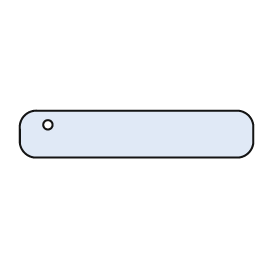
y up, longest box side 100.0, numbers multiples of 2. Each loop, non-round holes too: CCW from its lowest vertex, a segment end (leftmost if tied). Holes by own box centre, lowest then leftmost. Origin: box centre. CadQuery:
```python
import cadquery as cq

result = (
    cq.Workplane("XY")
    .moveTo(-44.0, -10.0)
    .lineTo(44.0, -10.0)
    .threePointArc((48.0, -8.0), (50.0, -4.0))
    .lineTo(50.0, 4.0)
    .threePointArc((48.0, 8.0), (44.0, 10.0))
    .lineTo(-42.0, 10.0)
    .threePointArc((-48.0, 8.0), (-50.0, 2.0))
    .lineTo(-50.0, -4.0)
    .threePointArc((-48.0, -8.0), (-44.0, -10.0))
    .close()
    .moveTo(-38.0, 4.0)
    .circle(2.0)
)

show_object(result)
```